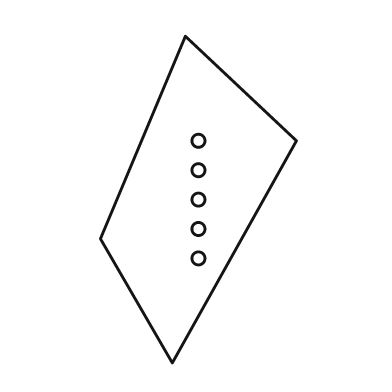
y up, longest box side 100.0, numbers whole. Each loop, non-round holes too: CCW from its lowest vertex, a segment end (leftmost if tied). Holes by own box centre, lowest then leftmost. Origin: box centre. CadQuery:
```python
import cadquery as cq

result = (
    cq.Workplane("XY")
    .moveTo(-8.0, -50.0)
    .lineTo(30.0, 18.0)
    .lineTo(-4.0, 50.0)
    .lineTo(-30.0, -12.0)
    .close()
    .moveTo(0.0, -18.0)
    .circle(2.0)
    .moveTo(0.0, -9.0)
    .circle(2.0)
    .moveTo(0.0, 0.0)
    .circle(2.0)
    .moveTo(0.0, 9.0)
    .circle(2.0)
    .moveTo(0.0, 18.0)
    .circle(2.0)
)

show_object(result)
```